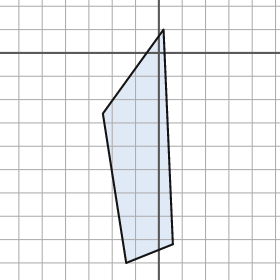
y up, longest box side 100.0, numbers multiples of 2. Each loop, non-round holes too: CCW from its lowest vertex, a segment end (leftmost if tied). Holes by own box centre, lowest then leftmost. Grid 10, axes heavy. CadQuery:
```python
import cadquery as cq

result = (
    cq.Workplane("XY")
    .moveTo(-14.0, -90.0)
    .lineTo(6.0, -82.0)
    .lineTo(2.0, 10.0)
    .lineTo(-24.0, -26.0)
    .close()
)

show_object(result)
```